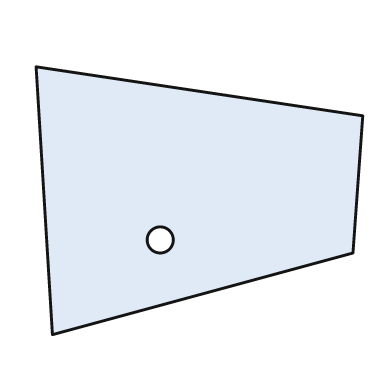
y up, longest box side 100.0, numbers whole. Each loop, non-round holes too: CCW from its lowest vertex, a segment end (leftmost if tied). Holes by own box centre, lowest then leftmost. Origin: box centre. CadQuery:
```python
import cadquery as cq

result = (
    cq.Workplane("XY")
    .moveTo(-45.0, -41.0)
    .lineTo(47.0, -16.0)
    .lineTo(50.0, 26.0)
    .lineTo(-50.0, 41.0)
    .close()
    .moveTo(-12.0, -12.0)
    .circle(4.0)
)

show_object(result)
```